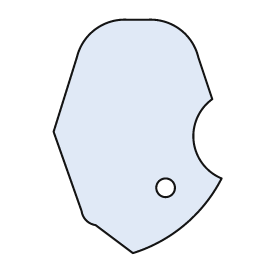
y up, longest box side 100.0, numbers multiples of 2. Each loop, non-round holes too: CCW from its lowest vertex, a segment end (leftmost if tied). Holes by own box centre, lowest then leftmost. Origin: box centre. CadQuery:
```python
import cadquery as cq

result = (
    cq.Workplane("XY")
    .moveTo(-2.0, -50.0)
    .threePointArc((20.0, -38.0), (36.0, -18.0))
    .threePointArc((24.0, -2.0), (32.0, 16.0))
    .lineTo(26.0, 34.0)
    .threePointArc((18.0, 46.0), (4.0, 50.0))
    .lineTo(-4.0, 50.0)
    .threePointArc((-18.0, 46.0), (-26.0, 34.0))
    .lineTo(-36.0, 2.0)
    .lineTo(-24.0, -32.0)
    .threePointArc((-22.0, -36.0), (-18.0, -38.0))
    .close()
    .moveTo(12.0, -22.0)
    .circle(4.0)
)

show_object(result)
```